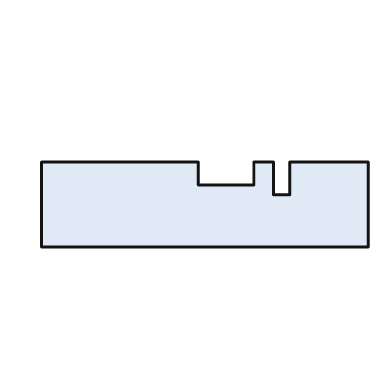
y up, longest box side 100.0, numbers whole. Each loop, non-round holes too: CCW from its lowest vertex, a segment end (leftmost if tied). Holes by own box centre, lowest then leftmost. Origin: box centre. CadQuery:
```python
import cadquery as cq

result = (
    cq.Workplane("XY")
    .moveTo(-50.0, -13.0)
    .lineTo(50.0, -13.0)
    .lineTo(50.0, 13.0)
    .lineTo(26.0, 13.0)
    .lineTo(26.0, 3.0)
    .lineTo(21.0, 3.0)
    .lineTo(21.0, 13.0)
    .lineTo(15.0, 13.0)
    .lineTo(15.0, 6.0)
    .lineTo(-2.0, 6.0)
    .lineTo(-2.0, 13.0)
    .lineTo(-50.0, 13.0)
    .close()
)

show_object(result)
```